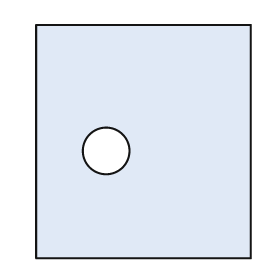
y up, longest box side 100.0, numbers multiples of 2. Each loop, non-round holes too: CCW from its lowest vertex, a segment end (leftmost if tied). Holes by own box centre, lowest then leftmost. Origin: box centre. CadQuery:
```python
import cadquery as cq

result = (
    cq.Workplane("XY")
    .moveTo(-46.0, -50.0)
    .lineTo(46.0, -50.0)
    .lineTo(46.0, 50.0)
    .lineTo(-46.0, 50.0)
    .close()
    .moveTo(-16.0, -4.0)
    .circle(10.0)
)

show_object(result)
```